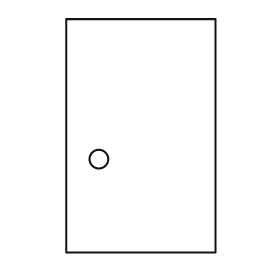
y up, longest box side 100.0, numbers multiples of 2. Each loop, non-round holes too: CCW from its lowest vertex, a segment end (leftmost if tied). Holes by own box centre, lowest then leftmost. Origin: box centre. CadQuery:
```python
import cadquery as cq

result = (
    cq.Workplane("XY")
    .moveTo(-32.0, -50.0)
    .lineTo(32.0, -50.0)
    .lineTo(32.0, 50.0)
    .lineTo(-32.0, 50.0)
    .close()
    .moveTo(-18.0, -10.0)
    .circle(4.0)
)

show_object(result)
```